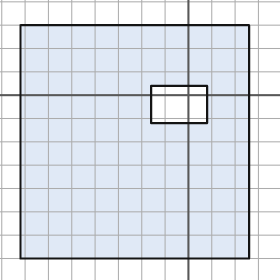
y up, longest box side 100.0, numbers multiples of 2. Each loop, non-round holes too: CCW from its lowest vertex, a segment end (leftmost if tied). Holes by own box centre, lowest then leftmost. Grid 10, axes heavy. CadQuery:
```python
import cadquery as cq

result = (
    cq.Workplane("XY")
    .moveTo(-72.0, -70.0)
    .lineTo(26.0, -70.0)
    .lineTo(26.0, 30.0)
    .lineTo(-72.0, 30.0)
    .close()
    .moveTo(-16.0, -12.0)
    .lineTo(8.0, -12.0)
    .lineTo(8.0, 4.0)
    .lineTo(-16.0, 4.0)
    .close()
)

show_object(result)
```